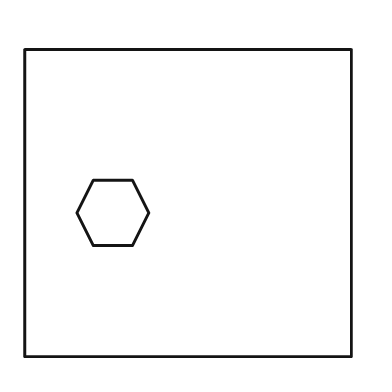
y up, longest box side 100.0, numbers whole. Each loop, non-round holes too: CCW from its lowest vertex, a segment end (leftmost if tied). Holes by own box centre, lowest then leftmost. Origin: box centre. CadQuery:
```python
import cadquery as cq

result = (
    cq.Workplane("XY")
    .moveTo(-50.0, -47.0)
    .lineTo(50.0, -47.0)
    .lineTo(50.0, 47.0)
    .lineTo(-50.0, 47.0)
    .close()
    .moveTo(-29.0, -13.0)
    .lineTo(-17.0, -13.0)
    .lineTo(-12.0, -3.0)
    .lineTo(-17.0, 7.0)
    .lineTo(-29.0, 7.0)
    .lineTo(-34.0, -3.0)
    .close()
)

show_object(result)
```